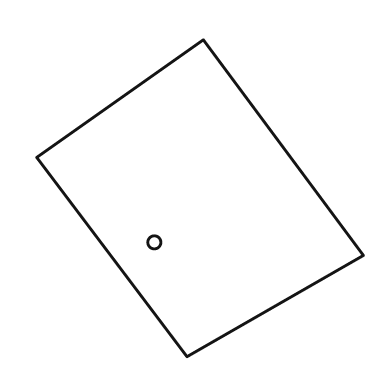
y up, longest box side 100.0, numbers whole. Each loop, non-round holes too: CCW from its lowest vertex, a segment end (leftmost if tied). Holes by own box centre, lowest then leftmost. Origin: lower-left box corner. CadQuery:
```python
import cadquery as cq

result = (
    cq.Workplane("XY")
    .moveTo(46.0, 0.0)
    .lineTo(100.0, 31.0)
    .lineTo(51.0, 97.0)
    .lineTo(0.0, 61.0)
    .close()
    .moveTo(36.0, 35.0)
    .circle(2.0)
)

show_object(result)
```